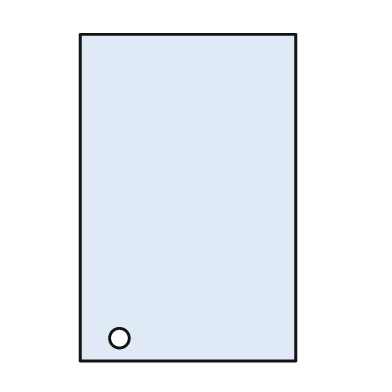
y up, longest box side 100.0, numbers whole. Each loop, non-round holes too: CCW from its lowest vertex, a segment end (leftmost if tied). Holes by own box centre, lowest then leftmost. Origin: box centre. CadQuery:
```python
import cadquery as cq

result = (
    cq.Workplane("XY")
    .moveTo(-33.0, -50.0)
    .lineTo(33.0, -50.0)
    .lineTo(33.0, 50.0)
    .lineTo(-33.0, 50.0)
    .close()
    .moveTo(-21.0, -43.0)
    .circle(3.0)
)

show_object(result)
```